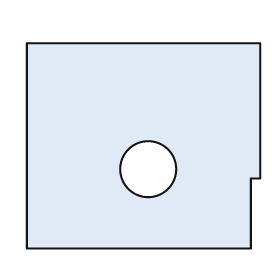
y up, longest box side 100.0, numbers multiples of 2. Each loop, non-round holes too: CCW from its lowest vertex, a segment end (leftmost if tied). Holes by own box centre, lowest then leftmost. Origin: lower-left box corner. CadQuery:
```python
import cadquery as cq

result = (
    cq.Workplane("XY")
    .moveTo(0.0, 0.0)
    .lineTo(96.0, 0.0)
    .lineTo(96.0, 30.0)
    .lineTo(100.0, 30.0)
    .lineTo(100.0, 88.0)
    .lineTo(0.0, 88.0)
    .close()
    .moveTo(52.0, 34.0)
    .circle(12.0)
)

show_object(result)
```